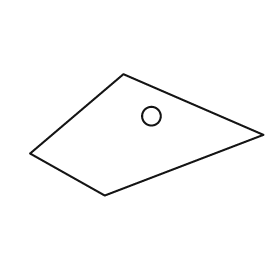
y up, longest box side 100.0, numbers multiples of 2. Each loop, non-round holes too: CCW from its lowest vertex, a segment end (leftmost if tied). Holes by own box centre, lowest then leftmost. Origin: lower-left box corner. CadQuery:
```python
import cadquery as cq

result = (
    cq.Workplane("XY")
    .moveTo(32.0, 0.0)
    .lineTo(100.0, 26.0)
    .lineTo(40.0, 52.0)
    .lineTo(0.0, 18.0)
    .close()
    .moveTo(52.0, 34.0)
    .circle(4.0)
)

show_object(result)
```